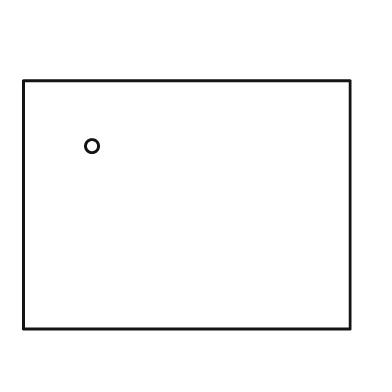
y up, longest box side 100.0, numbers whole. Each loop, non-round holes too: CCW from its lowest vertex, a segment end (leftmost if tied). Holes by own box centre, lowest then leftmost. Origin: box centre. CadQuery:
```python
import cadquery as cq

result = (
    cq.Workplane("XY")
    .moveTo(-50.0, -38.0)
    .lineTo(50.0, -38.0)
    .lineTo(50.0, 38.0)
    .lineTo(-50.0, 38.0)
    .close()
    .moveTo(-29.0, 18.0)
    .circle(2.0)
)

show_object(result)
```